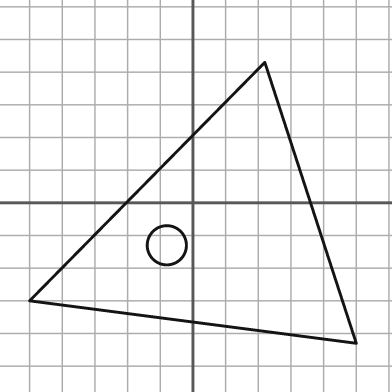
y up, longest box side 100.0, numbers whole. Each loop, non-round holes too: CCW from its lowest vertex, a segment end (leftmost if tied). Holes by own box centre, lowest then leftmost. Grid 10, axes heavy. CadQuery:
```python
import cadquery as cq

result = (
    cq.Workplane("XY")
    .moveTo(50.0, -43.0)
    .lineTo(22.0, 43.0)
    .lineTo(-50.0, -30.0)
    .close()
    .moveTo(-8.0, -13.0)
    .circle(6.0)
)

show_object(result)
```